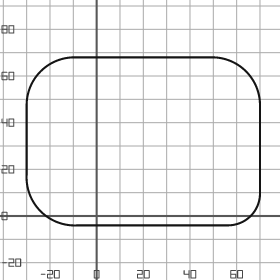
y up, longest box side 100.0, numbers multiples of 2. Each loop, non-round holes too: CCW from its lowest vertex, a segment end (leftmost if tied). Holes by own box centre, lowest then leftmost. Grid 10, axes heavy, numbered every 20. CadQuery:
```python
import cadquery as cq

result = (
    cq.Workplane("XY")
    .moveTo(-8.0, -4.0)
    .lineTo(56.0, -4.0)
    .threePointArc((66.0, 0.0), (70.0, 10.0))
    .lineTo(70.0, 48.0)
    .threePointArc((64.0, 62.0), (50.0, 68.0))
    .lineTo(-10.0, 68.0)
    .threePointArc((-24.0, 62.0), (-30.0, 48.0))
    .lineTo(-30.0, 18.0)
    .threePointArc((-24.0, 2.0), (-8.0, -4.0))
    .close()
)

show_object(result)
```